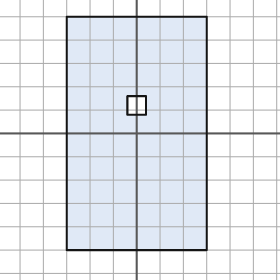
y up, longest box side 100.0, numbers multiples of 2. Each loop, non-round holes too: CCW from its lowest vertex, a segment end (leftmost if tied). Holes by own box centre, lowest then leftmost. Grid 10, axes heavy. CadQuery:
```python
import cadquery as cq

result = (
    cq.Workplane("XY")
    .moveTo(-30.0, -50.0)
    .lineTo(30.0, -50.0)
    .lineTo(30.0, 50.0)
    .lineTo(-30.0, 50.0)
    .close()
    .moveTo(-4.0, 8.0)
    .lineTo(4.0, 8.0)
    .lineTo(4.0, 16.0)
    .lineTo(-4.0, 16.0)
    .close()
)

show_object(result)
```